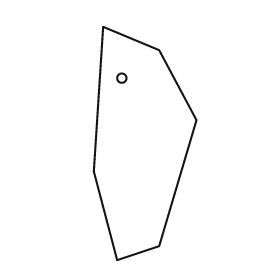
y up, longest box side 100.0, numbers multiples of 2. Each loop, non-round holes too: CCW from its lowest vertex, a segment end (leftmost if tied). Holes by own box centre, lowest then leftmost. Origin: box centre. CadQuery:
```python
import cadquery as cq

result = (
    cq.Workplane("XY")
    .moveTo(-12.0, -50.0)
    .lineTo(6.0, -44.0)
    .lineTo(22.0, 10.0)
    .lineTo(6.0, 40.0)
    .lineTo(-18.0, 50.0)
    .lineTo(-22.0, -12.0)
    .close()
    .moveTo(-10.0, 28.0)
    .circle(2.0)
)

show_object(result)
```